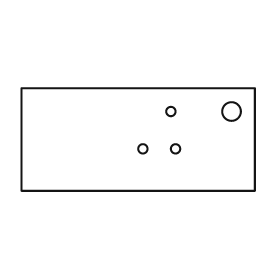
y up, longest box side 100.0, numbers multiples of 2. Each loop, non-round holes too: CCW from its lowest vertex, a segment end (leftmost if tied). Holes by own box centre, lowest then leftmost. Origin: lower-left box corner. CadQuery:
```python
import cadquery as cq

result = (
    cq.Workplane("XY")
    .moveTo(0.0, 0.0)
    .lineTo(100.0, 0.0)
    .lineTo(100.0, 44.0)
    .lineTo(0.0, 44.0)
    .close()
    .moveTo(52.0, 18.0)
    .circle(2.0)
    .moveTo(66.0, 18.0)
    .circle(2.0)
    .moveTo(64.0, 34.0)
    .circle(2.0)
    .moveTo(90.0, 34.0)
    .circle(4.0)
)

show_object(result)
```